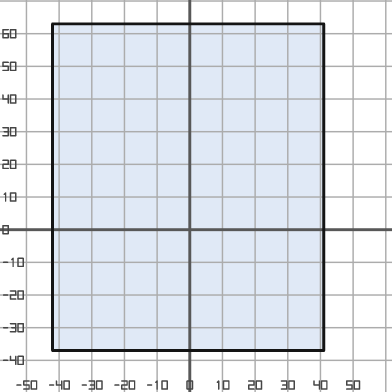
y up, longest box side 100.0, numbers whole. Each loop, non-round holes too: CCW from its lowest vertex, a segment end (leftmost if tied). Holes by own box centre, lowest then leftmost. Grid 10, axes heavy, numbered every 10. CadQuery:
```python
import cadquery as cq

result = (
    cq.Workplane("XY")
    .moveTo(-42.0, -37.0)
    .lineTo(41.0, -37.0)
    .lineTo(41.0, 63.0)
    .lineTo(-42.0, 63.0)
    .close()
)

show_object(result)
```